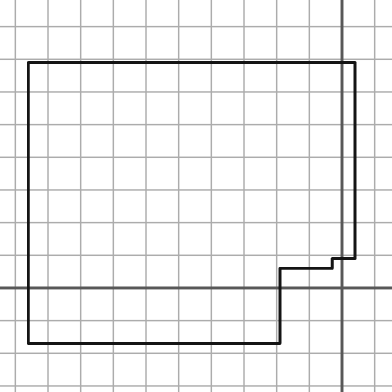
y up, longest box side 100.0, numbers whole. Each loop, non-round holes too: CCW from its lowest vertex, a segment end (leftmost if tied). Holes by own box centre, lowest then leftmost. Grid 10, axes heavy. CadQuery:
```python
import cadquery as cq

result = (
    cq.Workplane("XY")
    .moveTo(-96.0, -17.0)
    .lineTo(-19.0, -17.0)
    .lineTo(-19.0, 6.0)
    .lineTo(-3.0, 6.0)
    .lineTo(-3.0, 9.0)
    .lineTo(4.0, 9.0)
    .lineTo(4.0, 69.0)
    .lineTo(-96.0, 69.0)
    .close()
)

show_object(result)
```